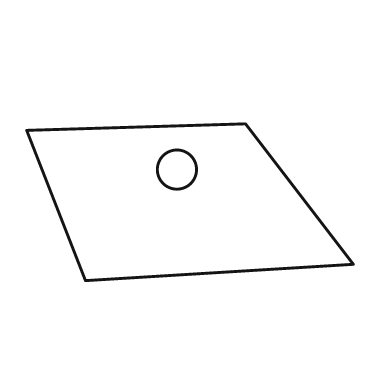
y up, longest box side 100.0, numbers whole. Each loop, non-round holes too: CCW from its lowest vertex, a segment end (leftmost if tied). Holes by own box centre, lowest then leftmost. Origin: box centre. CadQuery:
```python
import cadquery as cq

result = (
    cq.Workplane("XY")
    .moveTo(-32.0, -24.0)
    .lineTo(50.0, -19.0)
    .lineTo(17.0, 24.0)
    .lineTo(-50.0, 22.0)
    .close()
    .moveTo(-4.0, 10.0)
    .circle(6.0)
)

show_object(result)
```